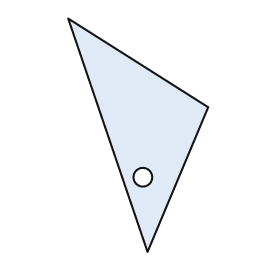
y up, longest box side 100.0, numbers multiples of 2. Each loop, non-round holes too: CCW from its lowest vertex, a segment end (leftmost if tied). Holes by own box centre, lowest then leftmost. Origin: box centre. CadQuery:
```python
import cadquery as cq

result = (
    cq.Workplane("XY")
    .moveTo(4.0, -50.0)
    .lineTo(30.0, 12.0)
    .lineTo(-30.0, 50.0)
    .close()
    .moveTo(2.0, -18.0)
    .circle(4.0)
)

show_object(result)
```